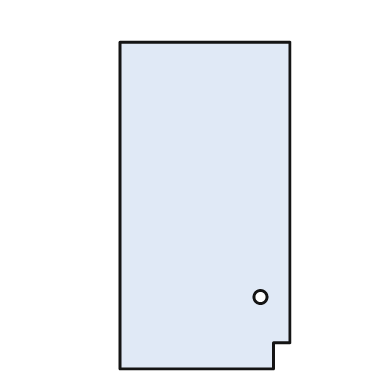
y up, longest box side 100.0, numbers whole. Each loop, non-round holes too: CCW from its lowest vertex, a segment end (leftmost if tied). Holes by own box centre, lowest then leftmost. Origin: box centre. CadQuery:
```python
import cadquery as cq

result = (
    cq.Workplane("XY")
    .moveTo(-26.0, -50.0)
    .lineTo(21.0, -50.0)
    .lineTo(21.0, -42.0)
    .lineTo(26.0, -42.0)
    .lineTo(26.0, 50.0)
    .lineTo(-26.0, 50.0)
    .close()
    .moveTo(17.0, -28.0)
    .circle(2.0)
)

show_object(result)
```